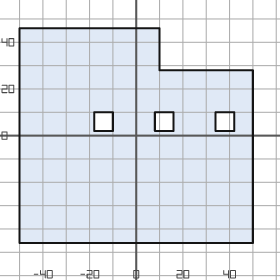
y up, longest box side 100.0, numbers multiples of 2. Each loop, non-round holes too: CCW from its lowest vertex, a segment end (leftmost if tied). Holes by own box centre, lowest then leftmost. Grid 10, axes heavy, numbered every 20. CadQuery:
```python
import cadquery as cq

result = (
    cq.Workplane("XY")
    .moveTo(-50.0, -46.0)
    .lineTo(50.0, -46.0)
    .lineTo(50.0, 28.0)
    .lineTo(10.0, 28.0)
    .lineTo(10.0, 46.0)
    .lineTo(-50.0, 46.0)
    .close()
    .moveTo(-18.0, 2.0)
    .lineTo(-10.0, 2.0)
    .lineTo(-10.0, 10.0)
    .lineTo(-18.0, 10.0)
    .close()
    .moveTo(8.0, 2.0)
    .lineTo(16.0, 2.0)
    .lineTo(16.0, 10.0)
    .lineTo(8.0, 10.0)
    .close()
    .moveTo(34.0, 2.0)
    .lineTo(42.0, 2.0)
    .lineTo(42.0, 10.0)
    .lineTo(34.0, 10.0)
    .close()
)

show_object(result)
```